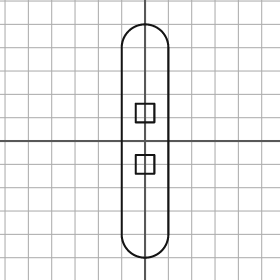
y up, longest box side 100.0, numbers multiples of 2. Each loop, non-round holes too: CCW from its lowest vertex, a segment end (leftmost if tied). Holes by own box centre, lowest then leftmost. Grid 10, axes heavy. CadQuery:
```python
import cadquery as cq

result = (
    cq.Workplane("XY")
    .moveTo(-10.0, -40.0)
    .threePointArc((0.0, -50.0), (10.0, -40.0))
    .lineTo(10.0, 40.0)
    .threePointArc((0.0, 50.0), (-10.0, 40.0))
    .close()
    .moveTo(-4.0, -14.0)
    .lineTo(4.0, -14.0)
    .lineTo(4.0, -6.0)
    .lineTo(-4.0, -6.0)
    .close()
    .moveTo(-4.0, 8.0)
    .lineTo(4.0, 8.0)
    .lineTo(4.0, 16.0)
    .lineTo(-4.0, 16.0)
    .close()
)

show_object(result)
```